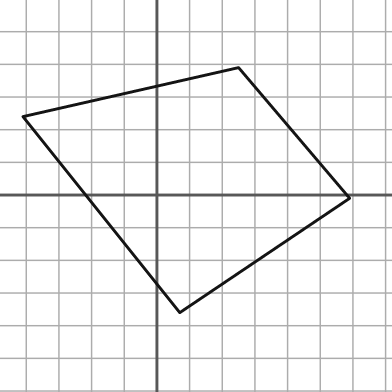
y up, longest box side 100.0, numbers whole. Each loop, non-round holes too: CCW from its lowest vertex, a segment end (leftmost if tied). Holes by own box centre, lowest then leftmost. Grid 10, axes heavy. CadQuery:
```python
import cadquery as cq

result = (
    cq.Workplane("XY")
    .moveTo(7.0, -36.0)
    .lineTo(59.0, -1.0)
    .lineTo(25.0, 39.0)
    .lineTo(-41.0, 24.0)
    .close()
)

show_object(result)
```